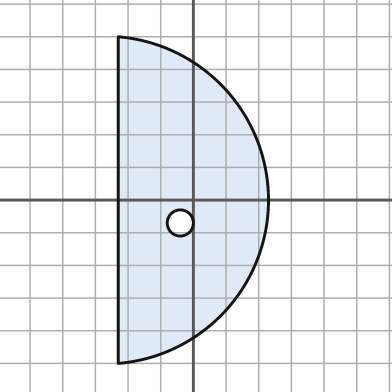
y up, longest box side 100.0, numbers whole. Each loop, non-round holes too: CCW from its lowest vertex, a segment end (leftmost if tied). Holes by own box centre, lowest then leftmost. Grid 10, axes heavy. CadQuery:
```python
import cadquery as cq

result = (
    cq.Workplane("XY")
    .moveTo(-23.0, -50.0)
    .threePointArc((23.0, 0.0), (-23.0, 50.0))
    .close()
    .moveTo(-4.0, -7.0)
    .circle(4.0)
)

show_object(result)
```